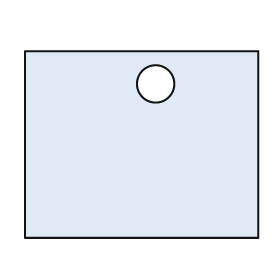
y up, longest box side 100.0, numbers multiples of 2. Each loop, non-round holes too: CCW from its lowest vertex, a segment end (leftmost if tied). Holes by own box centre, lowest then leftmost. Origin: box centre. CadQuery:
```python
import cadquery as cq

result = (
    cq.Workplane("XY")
    .moveTo(-50.0, -40.0)
    .lineTo(50.0, -40.0)
    .lineTo(50.0, 40.0)
    .lineTo(-50.0, 40.0)
    .close()
    .moveTo(6.0, 26.0)
    .circle(8.0)
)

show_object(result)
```